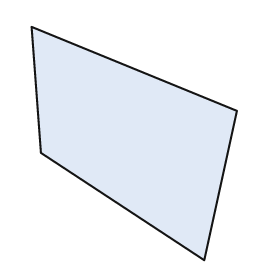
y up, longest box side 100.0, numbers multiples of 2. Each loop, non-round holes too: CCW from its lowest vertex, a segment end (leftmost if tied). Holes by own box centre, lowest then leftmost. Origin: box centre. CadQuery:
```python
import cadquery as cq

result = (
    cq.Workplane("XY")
    .moveTo(30.0, -50.0)
    .lineTo(44.0, 14.0)
    .lineTo(-44.0, 50.0)
    .lineTo(-40.0, -4.0)
    .close()
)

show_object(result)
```